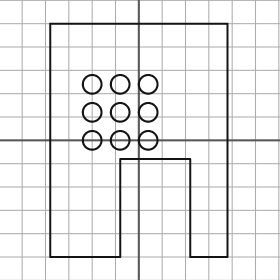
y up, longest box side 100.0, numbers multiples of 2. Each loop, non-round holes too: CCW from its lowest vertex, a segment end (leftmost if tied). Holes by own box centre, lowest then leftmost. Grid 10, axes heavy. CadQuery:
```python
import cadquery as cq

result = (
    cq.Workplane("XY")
    .moveTo(-38.0, -50.0)
    .lineTo(-8.0, -50.0)
    .lineTo(-8.0, -8.0)
    .lineTo(22.0, -8.0)
    .lineTo(22.0, -50.0)
    .lineTo(38.0, -50.0)
    .lineTo(38.0, 50.0)
    .lineTo(-38.0, 50.0)
    .close()
    .moveTo(-20.0, 0.0)
    .circle(4.0)
    .moveTo(-8.0, 0.0)
    .circle(4.0)
    .moveTo(4.0, 0.0)
    .circle(4.0)
    .moveTo(-20.0, 12.0)
    .circle(4.0)
    .moveTo(-8.0, 12.0)
    .circle(4.0)
    .moveTo(4.0, 12.0)
    .circle(4.0)
    .moveTo(-20.0, 24.0)
    .circle(4.0)
    .moveTo(-8.0, 24.0)
    .circle(4.0)
    .moveTo(4.0, 24.0)
    .circle(4.0)
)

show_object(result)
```